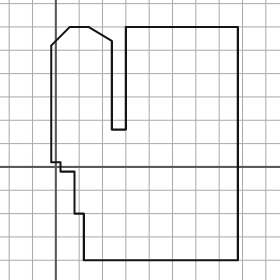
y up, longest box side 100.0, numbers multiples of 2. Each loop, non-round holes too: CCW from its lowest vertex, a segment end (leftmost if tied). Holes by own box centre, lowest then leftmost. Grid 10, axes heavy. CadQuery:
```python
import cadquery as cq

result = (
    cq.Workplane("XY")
    .moveTo(12.0, -40.0)
    .lineTo(78.0, -40.0)
    .lineTo(78.0, 60.0)
    .lineTo(30.0, 60.0)
    .lineTo(30.0, 16.0)
    .lineTo(24.0, 16.0)
    .lineTo(24.0, 54.0)
    .lineTo(14.0, 60.0)
    .lineTo(6.0, 60.0)
    .lineTo(-2.0, 52.0)
    .lineTo(-2.0, 2.0)
    .lineTo(2.0, 2.0)
    .lineTo(2.0, -2.0)
    .lineTo(8.0, -2.0)
    .lineTo(8.0, -20.0)
    .lineTo(12.0, -20.0)
    .close()
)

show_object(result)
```